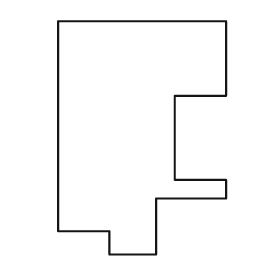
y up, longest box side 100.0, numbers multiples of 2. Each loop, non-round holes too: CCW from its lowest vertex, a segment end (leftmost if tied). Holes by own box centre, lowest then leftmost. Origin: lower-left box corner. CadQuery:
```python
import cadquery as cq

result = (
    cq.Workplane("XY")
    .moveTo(22.0, 0.0)
    .lineTo(42.0, 0.0)
    .lineTo(42.0, 24.0)
    .lineTo(72.0, 24.0)
    .lineTo(72.0, 32.0)
    .lineTo(50.0, 32.0)
    .lineTo(50.0, 68.0)
    .lineTo(72.0, 68.0)
    .lineTo(72.0, 100.0)
    .lineTo(0.0, 100.0)
    .lineTo(0.0, 10.0)
    .lineTo(22.0, 10.0)
    .close()
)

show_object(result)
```